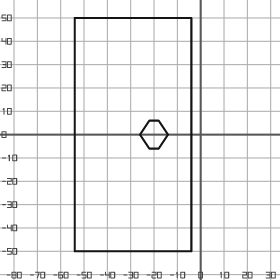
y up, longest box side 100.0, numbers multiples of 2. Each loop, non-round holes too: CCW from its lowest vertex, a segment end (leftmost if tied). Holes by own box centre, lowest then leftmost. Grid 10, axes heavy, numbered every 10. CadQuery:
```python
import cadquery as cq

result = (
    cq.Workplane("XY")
    .moveTo(-54.0, -50.0)
    .lineTo(-4.0, -50.0)
    .lineTo(-4.0, 50.0)
    .lineTo(-54.0, 50.0)
    .close()
    .moveTo(-22.0, -6.0)
    .lineTo(-18.0, -6.0)
    .lineTo(-14.0, 0.0)
    .lineTo(-18.0, 6.0)
    .lineTo(-22.0, 6.0)
    .lineTo(-26.0, 0.0)
    .close()
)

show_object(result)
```